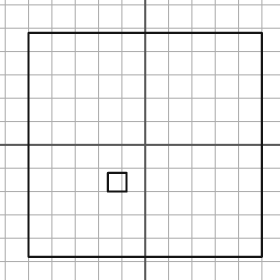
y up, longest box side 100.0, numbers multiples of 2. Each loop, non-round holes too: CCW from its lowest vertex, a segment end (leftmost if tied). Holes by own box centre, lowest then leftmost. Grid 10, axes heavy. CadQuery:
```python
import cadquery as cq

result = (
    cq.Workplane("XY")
    .moveTo(-50.0, -48.0)
    .lineTo(50.0, -48.0)
    .lineTo(50.0, 48.0)
    .lineTo(-50.0, 48.0)
    .close()
    .moveTo(-16.0, -20.0)
    .lineTo(-8.0, -20.0)
    .lineTo(-8.0, -12.0)
    .lineTo(-16.0, -12.0)
    .close()
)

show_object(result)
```